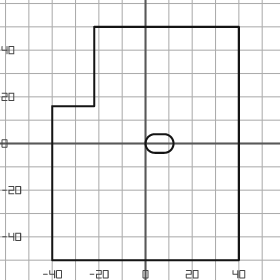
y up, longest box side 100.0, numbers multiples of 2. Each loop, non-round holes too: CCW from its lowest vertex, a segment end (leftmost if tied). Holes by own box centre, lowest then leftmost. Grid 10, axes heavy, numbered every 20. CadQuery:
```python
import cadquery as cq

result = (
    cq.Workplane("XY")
    .moveTo(-40.0, -50.0)
    .lineTo(40.0, -50.0)
    .lineTo(40.0, 50.0)
    .lineTo(-22.0, 50.0)
    .lineTo(-22.0, 16.0)
    .lineTo(-40.0, 16.0)
    .close()
    .moveTo(4.0, -4.0)
    .lineTo(8.0, -4.0)
    .threePointArc((12.0, 0.0), (8.0, 4.0))
    .lineTo(4.0, 4.0)
    .threePointArc((0.0, 0.0), (4.0, -4.0))
    .close()
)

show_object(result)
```